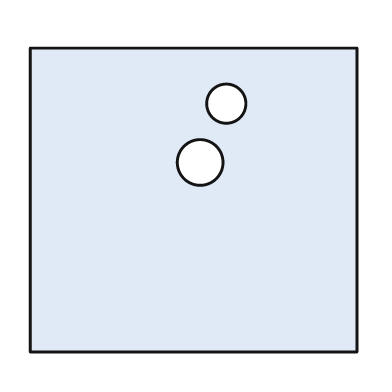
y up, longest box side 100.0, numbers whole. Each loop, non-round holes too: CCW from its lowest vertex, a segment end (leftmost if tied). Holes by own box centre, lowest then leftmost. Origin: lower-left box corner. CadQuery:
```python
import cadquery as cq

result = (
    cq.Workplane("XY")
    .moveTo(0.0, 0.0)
    .lineTo(100.0, 0.0)
    .lineTo(100.0, 93.0)
    .lineTo(0.0, 93.0)
    .close()
    .moveTo(52.0, 58.0)
    .circle(7.0)
    .moveTo(60.0, 76.0)
    .circle(6.0)
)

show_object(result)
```